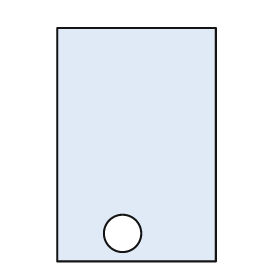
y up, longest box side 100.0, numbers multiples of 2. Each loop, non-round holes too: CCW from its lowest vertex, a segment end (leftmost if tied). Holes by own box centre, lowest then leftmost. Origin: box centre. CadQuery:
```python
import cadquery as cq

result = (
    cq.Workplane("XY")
    .moveTo(-34.0, -50.0)
    .lineTo(34.0, -50.0)
    .lineTo(34.0, 50.0)
    .lineTo(-34.0, 50.0)
    .close()
    .moveTo(-6.0, -38.0)
    .circle(8.0)
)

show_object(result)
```